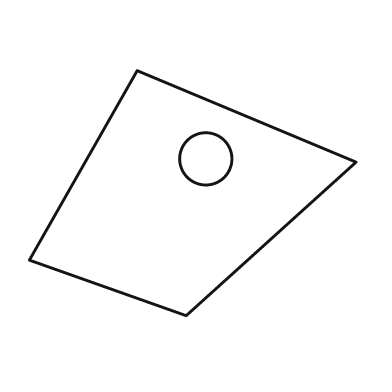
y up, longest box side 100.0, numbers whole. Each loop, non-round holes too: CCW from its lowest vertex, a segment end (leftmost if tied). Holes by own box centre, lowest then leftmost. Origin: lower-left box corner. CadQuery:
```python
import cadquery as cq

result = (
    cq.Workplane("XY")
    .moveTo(48.0, 0.0)
    .lineTo(100.0, 47.0)
    .lineTo(33.0, 75.0)
    .lineTo(0.0, 17.0)
    .close()
    .moveTo(54.0, 48.0)
    .circle(8.0)
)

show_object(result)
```